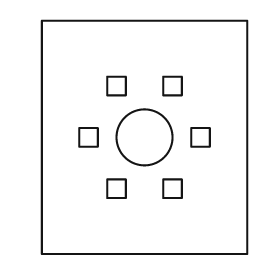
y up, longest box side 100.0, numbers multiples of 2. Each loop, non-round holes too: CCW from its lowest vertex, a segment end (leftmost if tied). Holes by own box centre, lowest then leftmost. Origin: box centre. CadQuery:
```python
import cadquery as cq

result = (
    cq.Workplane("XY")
    .moveTo(-44.0, -50.0)
    .lineTo(44.0, -50.0)
    .lineTo(44.0, 50.0)
    .lineTo(-44.0, 50.0)
    .close()
    .moveTo(-16.0, -26.0)
    .lineTo(-8.0, -26.0)
    .lineTo(-8.0, -18.0)
    .lineTo(-16.0, -18.0)
    .close()
    .moveTo(8.0, -26.0)
    .lineTo(16.0, -26.0)
    .lineTo(16.0, -18.0)
    .lineTo(8.0, -18.0)
    .close()
    .moveTo(-28.0, -4.0)
    .lineTo(-20.0, -4.0)
    .lineTo(-20.0, 4.0)
    .lineTo(-28.0, 4.0)
    .close()
    .moveTo(0.0, 0.0)
    .circle(12.0)
    .moveTo(20.0, -4.0)
    .lineTo(28.0, -4.0)
    .lineTo(28.0, 4.0)
    .lineTo(20.0, 4.0)
    .close()
    .moveTo(-16.0, 18.0)
    .lineTo(-8.0, 18.0)
    .lineTo(-8.0, 26.0)
    .lineTo(-16.0, 26.0)
    .close()
    .moveTo(8.0, 18.0)
    .lineTo(16.0, 18.0)
    .lineTo(16.0, 26.0)
    .lineTo(8.0, 26.0)
    .close()
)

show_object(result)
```